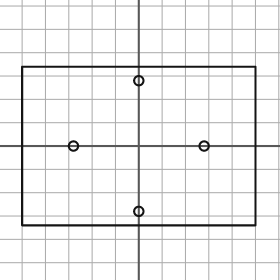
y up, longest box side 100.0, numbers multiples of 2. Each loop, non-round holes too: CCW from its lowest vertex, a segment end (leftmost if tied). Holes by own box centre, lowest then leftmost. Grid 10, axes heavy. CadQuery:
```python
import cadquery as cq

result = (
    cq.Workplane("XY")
    .moveTo(-50.0, -34.0)
    .lineTo(50.0, -34.0)
    .lineTo(50.0, 34.0)
    .lineTo(-50.0, 34.0)
    .close()
    .moveTo(0.0, -28.0)
    .circle(2.0)
    .moveTo(-28.0, 0.0)
    .circle(2.0)
    .moveTo(28.0, 0.0)
    .circle(2.0)
    .moveTo(0.0, 28.0)
    .circle(2.0)
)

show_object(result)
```